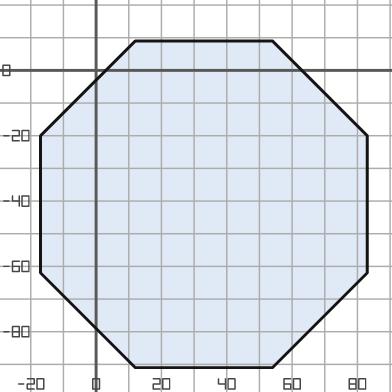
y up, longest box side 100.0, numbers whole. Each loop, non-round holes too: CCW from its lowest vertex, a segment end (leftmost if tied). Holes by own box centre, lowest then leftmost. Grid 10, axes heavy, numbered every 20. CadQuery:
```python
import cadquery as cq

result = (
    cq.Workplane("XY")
    .moveTo(12.0, -91.0)
    .lineTo(54.0, -91.0)
    .lineTo(83.0, -62.0)
    .lineTo(83.0, -20.0)
    .lineTo(54.0, 9.0)
    .lineTo(12.0, 9.0)
    .lineTo(-17.0, -20.0)
    .lineTo(-17.0, -62.0)
    .close()
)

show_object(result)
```